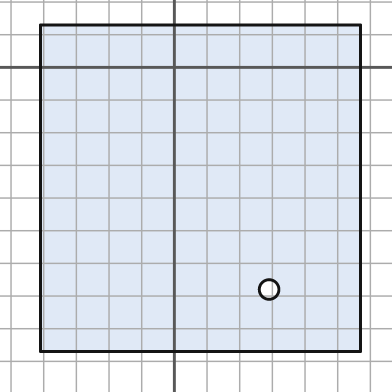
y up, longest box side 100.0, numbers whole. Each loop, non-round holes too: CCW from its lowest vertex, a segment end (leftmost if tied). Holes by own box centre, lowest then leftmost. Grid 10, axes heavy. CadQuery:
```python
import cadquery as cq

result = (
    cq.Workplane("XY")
    .moveTo(-41.0, -87.0)
    .lineTo(57.0, -87.0)
    .lineTo(57.0, 13.0)
    .lineTo(-41.0, 13.0)
    .close()
    .moveTo(29.0, -68.0)
    .circle(3.0)
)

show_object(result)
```